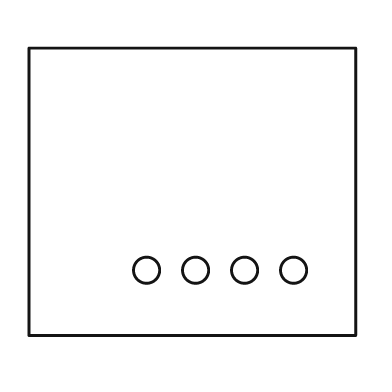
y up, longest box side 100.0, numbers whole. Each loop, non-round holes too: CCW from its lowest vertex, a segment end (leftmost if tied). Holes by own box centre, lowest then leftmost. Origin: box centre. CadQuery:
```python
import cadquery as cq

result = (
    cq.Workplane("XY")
    .moveTo(-50.0, -44.0)
    .lineTo(50.0, -44.0)
    .lineTo(50.0, 44.0)
    .lineTo(-50.0, 44.0)
    .close()
    .moveTo(-14.0, -24.0)
    .circle(4.0)
    .moveTo(1.0, -24.0)
    .circle(4.0)
    .moveTo(16.0, -24.0)
    .circle(4.0)
    .moveTo(31.0, -24.0)
    .circle(4.0)
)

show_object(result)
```